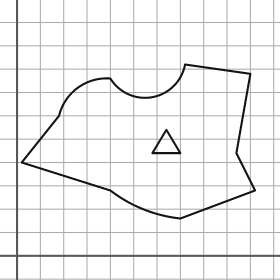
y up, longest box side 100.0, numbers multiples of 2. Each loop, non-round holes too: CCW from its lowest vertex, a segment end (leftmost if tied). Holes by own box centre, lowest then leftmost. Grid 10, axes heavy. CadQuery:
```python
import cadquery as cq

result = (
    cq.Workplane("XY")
    .moveTo(70.0, 16.0)
    .lineTo(102.0, 28.0)
    .lineTo(94.0, 44.0)
    .lineTo(100.0, 78.0)
    .lineTo(72.0, 82.0)
    .threePointArc((58.0, 68.0), (40.0, 76.0))
    .threePointArc((26.0, 72.0), (18.0, 60.0))
    .lineTo(2.0, 40.0)
    .lineTo(40.0, 28.0)
    .threePointArc((54.0, 20.0), (70.0, 16.0))
    .close()
    .moveTo(58.0, 44.0)
    .lineTo(70.0, 44.0)
    .lineTo(64.0, 54.0)
    .close()
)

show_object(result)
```